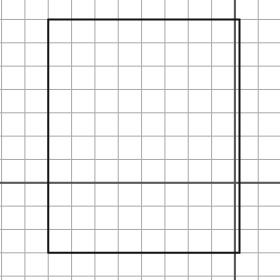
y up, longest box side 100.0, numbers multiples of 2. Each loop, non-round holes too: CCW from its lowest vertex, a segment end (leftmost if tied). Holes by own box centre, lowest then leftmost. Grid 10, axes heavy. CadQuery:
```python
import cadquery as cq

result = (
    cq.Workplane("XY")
    .moveTo(-80.0, -30.0)
    .lineTo(2.0, -30.0)
    .lineTo(2.0, 70.0)
    .lineTo(-80.0, 70.0)
    .close()
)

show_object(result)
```